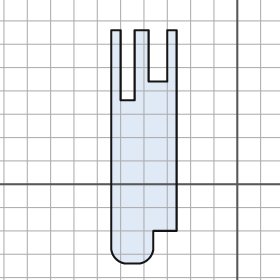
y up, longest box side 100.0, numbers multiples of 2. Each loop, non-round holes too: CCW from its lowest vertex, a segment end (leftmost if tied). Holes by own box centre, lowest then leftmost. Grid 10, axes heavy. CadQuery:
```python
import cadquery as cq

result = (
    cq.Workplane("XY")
    .moveTo(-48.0, -34.0)
    .lineTo(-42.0, -34.0)
    .threePointArc((-38.0, -32.0), (-36.0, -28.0))
    .lineTo(-36.0, -20.0)
    .lineTo(-26.0, -20.0)
    .lineTo(-26.0, 66.0)
    .lineTo(-30.0, 66.0)
    .lineTo(-30.0, 44.0)
    .lineTo(-38.0, 44.0)
    .lineTo(-38.0, 66.0)
    .lineTo(-44.0, 66.0)
    .lineTo(-44.0, 36.0)
    .lineTo(-50.0, 36.0)
    .lineTo(-50.0, 66.0)
    .lineTo(-54.0, 66.0)
    .lineTo(-54.0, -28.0)
    .threePointArc((-52.0, -32.0), (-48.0, -34.0))
    .close()
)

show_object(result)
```